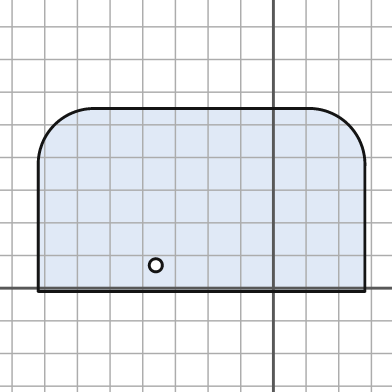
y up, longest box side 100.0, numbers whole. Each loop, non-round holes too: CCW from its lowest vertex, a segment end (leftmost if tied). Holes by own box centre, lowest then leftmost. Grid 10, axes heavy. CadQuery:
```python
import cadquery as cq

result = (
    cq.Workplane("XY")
    .moveTo(-72.0, -1.0)
    .lineTo(28.0, -1.0)
    .lineTo(28.0, 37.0)
    .threePointArc((23.0, 50.0), (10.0, 55.0))
    .lineTo(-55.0, 55.0)
    .threePointArc((-67.0, 50.0), (-72.0, 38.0))
    .close()
    .moveTo(-36.0, 7.0)
    .circle(2.0)
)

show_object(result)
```